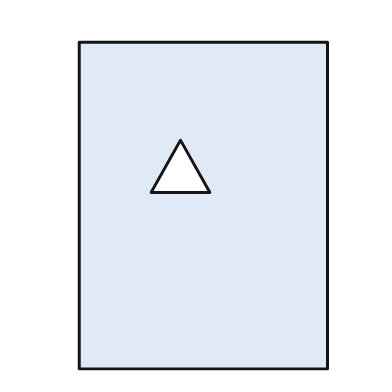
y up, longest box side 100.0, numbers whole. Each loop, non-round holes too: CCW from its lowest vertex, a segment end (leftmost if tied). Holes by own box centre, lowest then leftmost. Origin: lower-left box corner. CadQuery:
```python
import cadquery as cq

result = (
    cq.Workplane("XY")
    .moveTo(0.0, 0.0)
    .lineTo(76.0, 0.0)
    .lineTo(76.0, 100.0)
    .lineTo(0.0, 100.0)
    .close()
    .moveTo(22.0, 54.0)
    .lineTo(40.0, 54.0)
    .lineTo(31.0, 70.0)
    .close()
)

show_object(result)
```